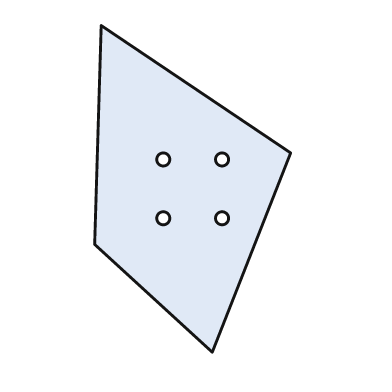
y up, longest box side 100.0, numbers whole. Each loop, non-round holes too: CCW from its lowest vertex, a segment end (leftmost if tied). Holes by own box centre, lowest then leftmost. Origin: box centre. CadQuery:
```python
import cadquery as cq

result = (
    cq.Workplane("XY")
    .moveTo(6.0, -50.0)
    .lineTo(30.0, 11.0)
    .lineTo(-28.0, 50.0)
    .lineTo(-30.0, -17.0)
    .close()
    .moveTo(-9.0, -9.0)
    .circle(2.0)
    .moveTo(9.0, -9.0)
    .circle(2.0)
    .moveTo(-9.0, 9.0)
    .circle(2.0)
    .moveTo(9.0, 9.0)
    .circle(2.0)
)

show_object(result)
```